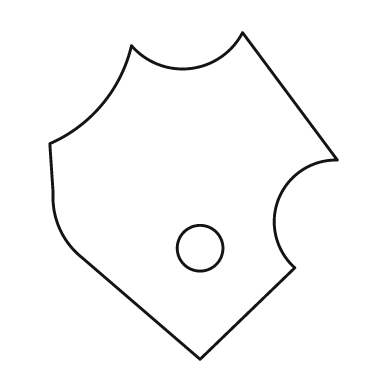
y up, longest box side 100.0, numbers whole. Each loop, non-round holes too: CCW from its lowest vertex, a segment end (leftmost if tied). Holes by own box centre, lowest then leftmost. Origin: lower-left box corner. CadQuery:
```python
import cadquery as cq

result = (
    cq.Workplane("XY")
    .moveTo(46.0, 0.0)
    .lineTo(75.0, 28.0)
    .threePointArc((70.0, 49.0), (88.0, 61.0))
    .lineTo(59.0, 100.0)
    .threePointArc((43.0, 89.0), (25.0, 96.0))
    .threePointArc((16.0, 78.0), (0.0, 66.0))
    .lineTo(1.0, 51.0)
    .threePointArc((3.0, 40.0), (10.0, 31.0))
    .close()
    .moveTo(46.0, 34.0)
    .circle(7.0)
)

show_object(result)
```